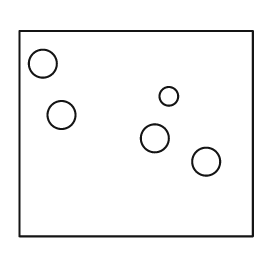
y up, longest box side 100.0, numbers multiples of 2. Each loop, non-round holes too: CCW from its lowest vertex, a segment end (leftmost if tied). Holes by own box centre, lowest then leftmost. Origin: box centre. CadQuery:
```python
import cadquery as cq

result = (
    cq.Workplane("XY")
    .moveTo(-50.0, -44.0)
    .lineTo(50.0, -44.0)
    .lineTo(50.0, 44.0)
    .lineTo(-50.0, 44.0)
    .close()
    .moveTo(30.0, -12.0)
    .circle(6.0)
    .moveTo(8.0, -2.0)
    .circle(6.0)
    .moveTo(-32.0, 8.0)
    .circle(6.0)
    .moveTo(14.0, 16.0)
    .circle(4.0)
    .moveTo(-40.0, 30.0)
    .circle(6.0)
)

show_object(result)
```